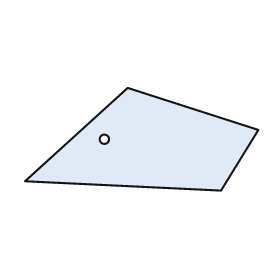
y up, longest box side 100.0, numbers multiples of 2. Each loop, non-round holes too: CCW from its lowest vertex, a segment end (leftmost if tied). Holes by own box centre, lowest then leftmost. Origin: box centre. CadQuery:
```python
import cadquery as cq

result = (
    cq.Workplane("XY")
    .moveTo(34.0, -22.0)
    .lineTo(50.0, 4.0)
    .lineTo(-6.0, 22.0)
    .lineTo(-50.0, -18.0)
    .close()
    .moveTo(-16.0, 0.0)
    .circle(2.0)
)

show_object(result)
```